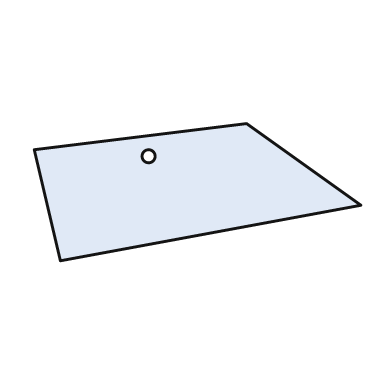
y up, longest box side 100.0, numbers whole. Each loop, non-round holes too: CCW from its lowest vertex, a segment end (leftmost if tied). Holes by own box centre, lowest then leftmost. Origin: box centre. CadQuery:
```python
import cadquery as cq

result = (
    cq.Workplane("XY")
    .moveTo(-42.0, -21.0)
    .lineTo(50.0, -4.0)
    .lineTo(15.0, 21.0)
    .lineTo(-50.0, 13.0)
    .close()
    .moveTo(-15.0, 11.0)
    .circle(2.0)
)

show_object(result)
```